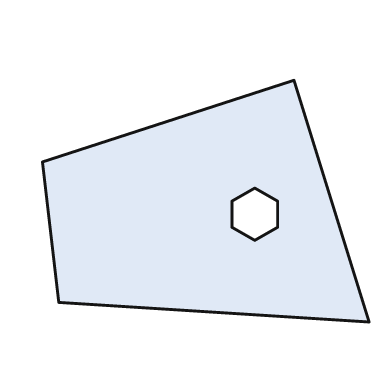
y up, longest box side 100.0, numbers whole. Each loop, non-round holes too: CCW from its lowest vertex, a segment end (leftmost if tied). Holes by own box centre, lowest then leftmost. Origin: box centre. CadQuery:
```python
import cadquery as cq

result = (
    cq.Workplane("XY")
    .moveTo(50.0, -37.0)
    .lineTo(27.0, 37.0)
    .lineTo(-50.0, 12.0)
    .lineTo(-45.0, -31.0)
    .close()
    .moveTo(15.0, -12.0)
    .lineTo(22.0, -8.0)
    .lineTo(22.0, 0.0)
    .lineTo(15.0, 4.0)
    .lineTo(8.0, 0.0)
    .lineTo(8.0, -8.0)
    .close()
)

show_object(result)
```